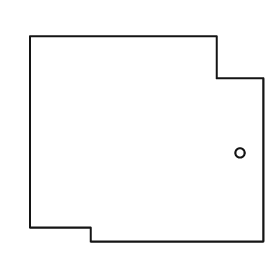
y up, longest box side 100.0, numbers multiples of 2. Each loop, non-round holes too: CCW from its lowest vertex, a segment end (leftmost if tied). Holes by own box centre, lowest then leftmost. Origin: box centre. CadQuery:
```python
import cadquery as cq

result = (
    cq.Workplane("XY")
    .moveTo(-24.0, -44.0)
    .lineTo(50.0, -44.0)
    .lineTo(50.0, 26.0)
    .lineTo(30.0, 26.0)
    .lineTo(30.0, 44.0)
    .lineTo(-50.0, 44.0)
    .lineTo(-50.0, -38.0)
    .lineTo(-24.0, -38.0)
    .close()
    .moveTo(40.0, -6.0)
    .circle(2.0)
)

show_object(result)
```